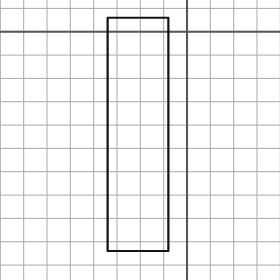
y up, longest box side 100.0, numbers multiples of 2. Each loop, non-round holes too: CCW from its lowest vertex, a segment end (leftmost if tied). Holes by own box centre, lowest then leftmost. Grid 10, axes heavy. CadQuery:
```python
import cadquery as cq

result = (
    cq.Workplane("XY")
    .moveTo(-34.0, -94.0)
    .lineTo(-8.0, -94.0)
    .lineTo(-8.0, 6.0)
    .lineTo(-34.0, 6.0)
    .close()
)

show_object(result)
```